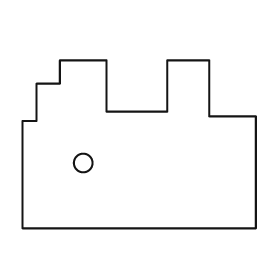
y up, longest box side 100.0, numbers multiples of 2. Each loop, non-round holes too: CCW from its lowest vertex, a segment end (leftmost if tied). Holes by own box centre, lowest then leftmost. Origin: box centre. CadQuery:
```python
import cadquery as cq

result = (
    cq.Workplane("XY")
    .moveTo(-50.0, -36.0)
    .lineTo(50.0, -36.0)
    .lineTo(50.0, 12.0)
    .lineTo(30.0, 12.0)
    .lineTo(30.0, 36.0)
    .lineTo(12.0, 36.0)
    .lineTo(12.0, 14.0)
    .lineTo(-14.0, 14.0)
    .lineTo(-14.0, 36.0)
    .lineTo(-34.0, 36.0)
    .lineTo(-34.0, 26.0)
    .lineTo(-44.0, 26.0)
    .lineTo(-44.0, 10.0)
    .lineTo(-50.0, 10.0)
    .close()
    .moveTo(-24.0, -8.0)
    .circle(4.0)
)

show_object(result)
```